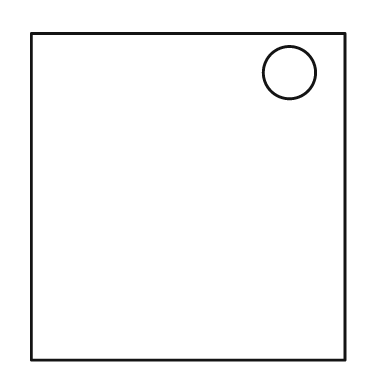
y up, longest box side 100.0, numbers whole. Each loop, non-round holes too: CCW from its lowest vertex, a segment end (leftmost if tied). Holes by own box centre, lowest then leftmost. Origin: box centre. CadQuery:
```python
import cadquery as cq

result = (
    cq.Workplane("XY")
    .moveTo(-48.0, -50.0)
    .lineTo(48.0, -50.0)
    .lineTo(48.0, 50.0)
    .lineTo(-48.0, 50.0)
    .close()
    .moveTo(31.0, 38.0)
    .circle(8.0)
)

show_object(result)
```